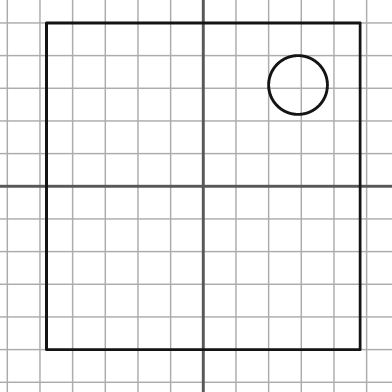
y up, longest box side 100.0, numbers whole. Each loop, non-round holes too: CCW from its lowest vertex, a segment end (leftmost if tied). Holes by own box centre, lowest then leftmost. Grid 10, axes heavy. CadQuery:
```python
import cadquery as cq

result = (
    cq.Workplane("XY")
    .moveTo(-48.0, -50.0)
    .lineTo(48.0, -50.0)
    .lineTo(48.0, 50.0)
    .lineTo(-48.0, 50.0)
    .close()
    .moveTo(29.0, 31.0)
    .circle(9.0)
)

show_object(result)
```